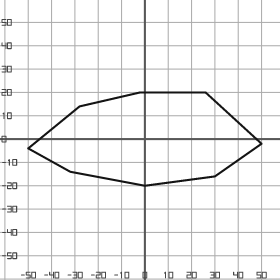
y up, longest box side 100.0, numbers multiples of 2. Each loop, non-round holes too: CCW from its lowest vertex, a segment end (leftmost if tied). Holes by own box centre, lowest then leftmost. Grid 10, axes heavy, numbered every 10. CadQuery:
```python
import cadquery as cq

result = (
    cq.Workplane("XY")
    .moveTo(0.0, -20.0)
    .lineTo(30.0, -16.0)
    .lineTo(50.0, -2.0)
    .lineTo(26.0, 20.0)
    .lineTo(-2.0, 20.0)
    .lineTo(-28.0, 14.0)
    .lineTo(-50.0, -4.0)
    .lineTo(-32.0, -14.0)
    .close()
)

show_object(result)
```